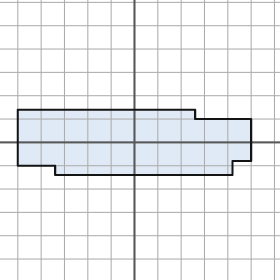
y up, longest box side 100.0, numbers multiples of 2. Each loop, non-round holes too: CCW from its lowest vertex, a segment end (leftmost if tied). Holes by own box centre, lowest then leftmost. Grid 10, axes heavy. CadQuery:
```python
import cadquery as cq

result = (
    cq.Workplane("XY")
    .moveTo(-34.0, -14.0)
    .lineTo(42.0, -14.0)
    .lineTo(42.0, -8.0)
    .lineTo(50.0, -8.0)
    .lineTo(50.0, 10.0)
    .lineTo(26.0, 10.0)
    .lineTo(26.0, 14.0)
    .lineTo(-50.0, 14.0)
    .lineTo(-50.0, -10.0)
    .lineTo(-34.0, -10.0)
    .close()
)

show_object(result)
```